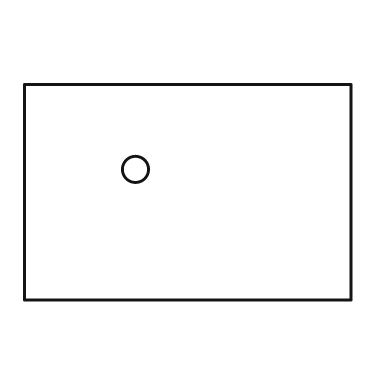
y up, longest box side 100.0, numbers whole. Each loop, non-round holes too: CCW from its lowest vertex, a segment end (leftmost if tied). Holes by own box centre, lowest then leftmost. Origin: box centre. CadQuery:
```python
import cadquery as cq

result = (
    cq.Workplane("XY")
    .moveTo(-50.0, -33.0)
    .lineTo(50.0, -33.0)
    .lineTo(50.0, 33.0)
    .lineTo(-50.0, 33.0)
    .close()
    .moveTo(-16.0, 7.0)
    .circle(4.0)
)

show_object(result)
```